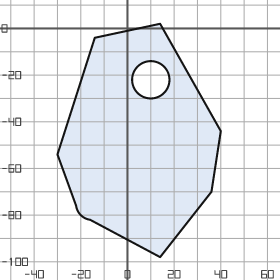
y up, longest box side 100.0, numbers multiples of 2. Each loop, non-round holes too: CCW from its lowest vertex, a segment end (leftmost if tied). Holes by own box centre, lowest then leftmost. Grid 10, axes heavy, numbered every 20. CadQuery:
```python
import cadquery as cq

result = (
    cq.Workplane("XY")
    .moveTo(14.0, -98.0)
    .lineTo(36.0, -70.0)
    .lineTo(40.0, -44.0)
    .lineTo(14.0, 2.0)
    .lineTo(-14.0, -4.0)
    .lineTo(-30.0, -54.0)
    .lineTo(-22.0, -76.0)
    .threePointArc((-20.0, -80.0), (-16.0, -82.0))
    .close()
    .moveTo(10.0, -22.0)
    .circle(8.0)
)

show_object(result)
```